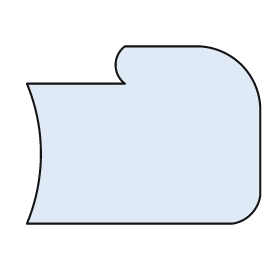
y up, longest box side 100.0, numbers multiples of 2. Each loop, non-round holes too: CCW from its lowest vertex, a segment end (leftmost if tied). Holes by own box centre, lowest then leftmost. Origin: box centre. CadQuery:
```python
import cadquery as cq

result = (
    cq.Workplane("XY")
    .moveTo(-50.0, -38.0)
    .lineTo(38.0, -38.0)
    .threePointArc((46.0, -34.0), (50.0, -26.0))
    .lineTo(50.0, 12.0)
    .threePointArc((42.0, 30.0), (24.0, 38.0))
    .lineTo(-8.0, 38.0)
    .threePointArc((-12.0, 30.0), (-8.0, 22.0))
    .lineTo(-50.0, 22.0)
    .threePointArc((-44.0, -8.0), (-50.0, -38.0))
    .close()
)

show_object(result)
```